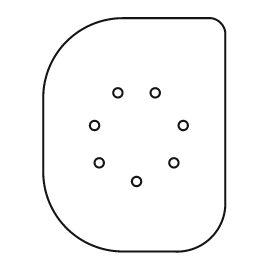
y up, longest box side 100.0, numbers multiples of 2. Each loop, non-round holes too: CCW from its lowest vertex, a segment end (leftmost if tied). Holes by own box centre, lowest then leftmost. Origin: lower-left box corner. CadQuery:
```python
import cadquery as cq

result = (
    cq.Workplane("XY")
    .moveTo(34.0, 0.0)
    .lineTo(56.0, 0.0)
    .threePointArc((72.0, 6.0), (78.0, 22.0))
    .lineTo(78.0, 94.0)
    .threePointArc((76.0, 98.0), (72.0, 100.0))
    .lineTo(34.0, 100.0)
    .threePointArc((10.0, 90.0), (0.0, 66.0))
    .lineTo(0.0, 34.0)
    .threePointArc((10.0, 10.0), (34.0, 0.0))
    .close()
    .moveTo(40.0, 30.0)
    .circle(2.0)
    .moveTo(24.0, 38.0)
    .circle(2.0)
    .moveTo(56.0, 38.0)
    .circle(2.0)
    .moveTo(22.0, 54.0)
    .circle(2.0)
    .moveTo(60.0, 54.0)
    .circle(2.0)
    .moveTo(32.0, 68.0)
    .circle(2.0)
    .moveTo(48.0, 68.0)
    .circle(2.0)
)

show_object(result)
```